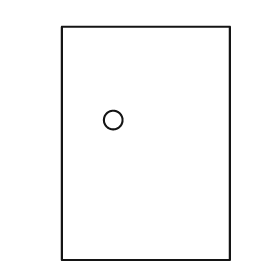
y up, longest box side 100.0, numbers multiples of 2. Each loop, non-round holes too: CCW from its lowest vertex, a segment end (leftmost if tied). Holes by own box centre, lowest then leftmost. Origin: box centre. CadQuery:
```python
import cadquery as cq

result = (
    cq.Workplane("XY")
    .moveTo(-36.0, -50.0)
    .lineTo(36.0, -50.0)
    .lineTo(36.0, 50.0)
    .lineTo(-36.0, 50.0)
    .close()
    .moveTo(-14.0, 10.0)
    .circle(4.0)
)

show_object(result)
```